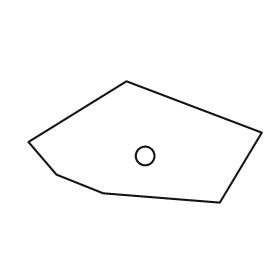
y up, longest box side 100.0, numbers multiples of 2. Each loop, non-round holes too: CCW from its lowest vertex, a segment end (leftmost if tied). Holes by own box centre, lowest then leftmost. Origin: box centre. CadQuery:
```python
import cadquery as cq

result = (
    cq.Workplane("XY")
    .moveTo(32.0, -26.0)
    .lineTo(50.0, 4.0)
    .lineTo(-8.0, 26.0)
    .lineTo(-50.0, 0.0)
    .lineTo(-38.0, -14.0)
    .lineTo(-18.0, -22.0)
    .close()
    .moveTo(0.0, -6.0)
    .circle(4.0)
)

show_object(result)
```